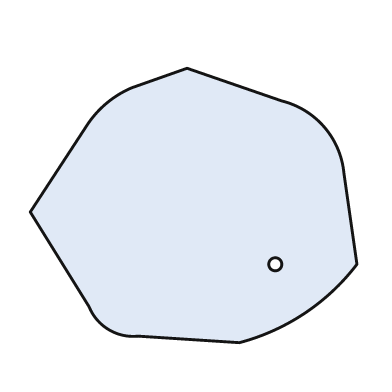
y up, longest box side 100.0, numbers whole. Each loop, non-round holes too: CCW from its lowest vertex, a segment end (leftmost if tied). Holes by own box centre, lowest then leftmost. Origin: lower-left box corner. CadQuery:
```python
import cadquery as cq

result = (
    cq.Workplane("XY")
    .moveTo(64.0, 0.0)
    .threePointArc((84.0, 9.0), (100.0, 24.0))
    .lineTo(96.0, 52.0)
    .threePointArc((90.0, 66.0), (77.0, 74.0))
    .lineTo(48.0, 84.0)
    .lineTo(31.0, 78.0)
    .threePointArc((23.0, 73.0), (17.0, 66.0))
    .lineTo(0.0, 40.0)
    .lineTo(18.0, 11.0)
    .threePointArc((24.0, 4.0), (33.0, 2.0))
    .close()
    .moveTo(75.0, 24.0)
    .circle(2.0)
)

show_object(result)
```